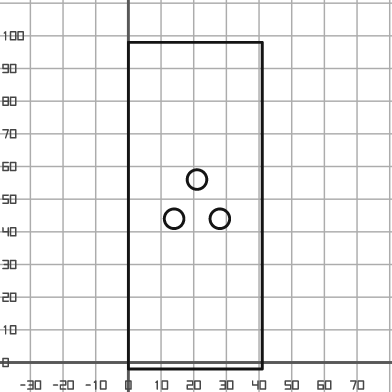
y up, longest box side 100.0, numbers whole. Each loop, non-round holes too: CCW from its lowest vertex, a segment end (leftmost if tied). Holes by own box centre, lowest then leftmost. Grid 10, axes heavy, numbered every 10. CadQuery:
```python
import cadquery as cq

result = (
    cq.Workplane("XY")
    .moveTo(0.0, -2.0)
    .lineTo(41.0, -2.0)
    .lineTo(41.0, 98.0)
    .lineTo(0.0, 98.0)
    .close()
    .moveTo(14.0, 44.0)
    .circle(3.0)
    .moveTo(28.0, 44.0)
    .circle(3.0)
    .moveTo(21.0, 56.0)
    .circle(3.0)
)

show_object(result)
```